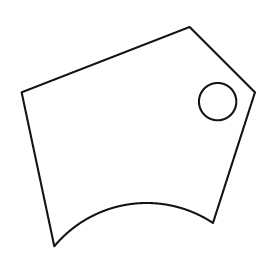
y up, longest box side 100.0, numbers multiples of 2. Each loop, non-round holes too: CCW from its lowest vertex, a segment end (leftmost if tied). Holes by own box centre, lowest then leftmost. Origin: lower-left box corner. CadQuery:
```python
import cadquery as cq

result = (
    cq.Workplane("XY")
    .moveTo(14.0, 0.0)
    .threePointArc((46.0, 18.0), (82.0, 10.0))
    .lineTo(100.0, 66.0)
    .lineTo(72.0, 94.0)
    .lineTo(0.0, 66.0)
    .close()
    .moveTo(84.0, 62.0)
    .circle(8.0)
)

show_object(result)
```